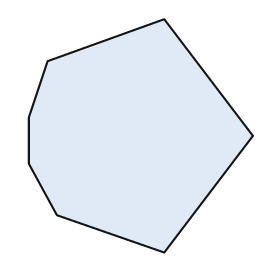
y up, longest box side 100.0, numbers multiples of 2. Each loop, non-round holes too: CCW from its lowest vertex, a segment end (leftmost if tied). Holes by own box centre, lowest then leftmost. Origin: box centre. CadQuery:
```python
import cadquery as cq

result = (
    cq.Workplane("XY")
    .moveTo(10.0, -50.0)
    .lineTo(48.0, 0.0)
    .lineTo(10.0, 50.0)
    .lineTo(-40.0, 32.0)
    .lineTo(-48.0, 8.0)
    .lineTo(-48.0, -12.0)
    .lineTo(-36.0, -34.0)
    .close()
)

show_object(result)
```